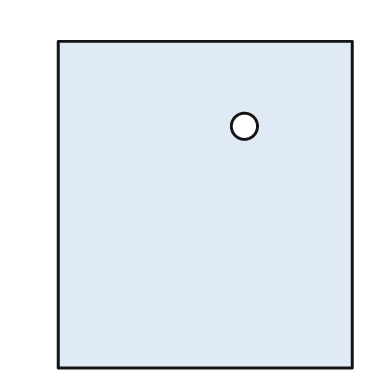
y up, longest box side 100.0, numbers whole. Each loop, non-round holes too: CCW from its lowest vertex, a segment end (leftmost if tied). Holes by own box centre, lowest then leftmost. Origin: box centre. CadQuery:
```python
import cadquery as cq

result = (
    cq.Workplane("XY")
    .moveTo(-45.0, -50.0)
    .lineTo(45.0, -50.0)
    .lineTo(45.0, 50.0)
    .lineTo(-45.0, 50.0)
    .close()
    .moveTo(12.0, 24.0)
    .circle(4.0)
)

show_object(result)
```